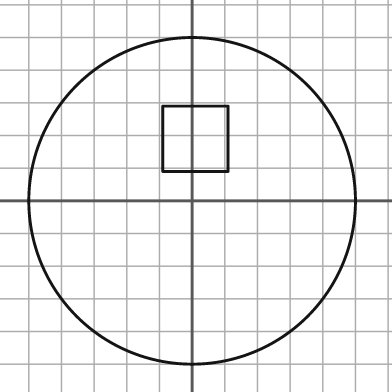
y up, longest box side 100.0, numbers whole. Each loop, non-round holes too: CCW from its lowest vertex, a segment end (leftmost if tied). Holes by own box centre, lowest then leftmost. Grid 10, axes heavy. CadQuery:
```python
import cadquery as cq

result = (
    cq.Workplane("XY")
    .moveTo(0.0, 0.0)
    .circle(50.0)
    .moveTo(-9.0, 9.0)
    .lineTo(11.0, 9.0)
    .lineTo(11.0, 29.0)
    .lineTo(-9.0, 29.0)
    .close()
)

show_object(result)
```